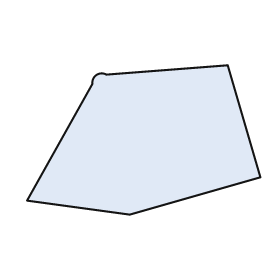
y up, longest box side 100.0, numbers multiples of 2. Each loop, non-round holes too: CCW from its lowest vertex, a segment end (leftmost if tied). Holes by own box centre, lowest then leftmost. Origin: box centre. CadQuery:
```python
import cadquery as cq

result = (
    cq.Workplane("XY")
    .moveTo(-6.0, -32.0)
    .lineTo(50.0, -16.0)
    .lineTo(36.0, 32.0)
    .lineTo(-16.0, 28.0)
    .threePointArc((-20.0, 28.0), (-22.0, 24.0))
    .lineTo(-50.0, -26.0)
    .close()
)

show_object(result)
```